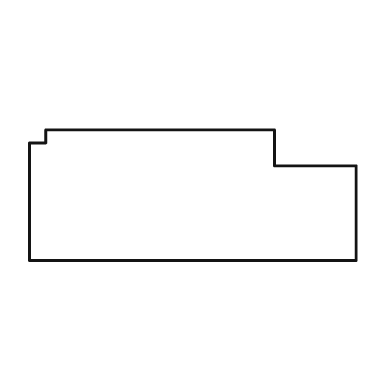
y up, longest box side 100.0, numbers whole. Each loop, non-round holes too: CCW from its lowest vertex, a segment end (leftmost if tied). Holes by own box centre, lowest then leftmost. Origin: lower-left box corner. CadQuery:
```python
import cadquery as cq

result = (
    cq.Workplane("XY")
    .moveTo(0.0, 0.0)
    .lineTo(100.0, 0.0)
    .lineTo(100.0, 29.0)
    .lineTo(75.0, 29.0)
    .lineTo(75.0, 40.0)
    .lineTo(5.0, 40.0)
    .lineTo(5.0, 36.0)
    .lineTo(0.0, 36.0)
    .close()
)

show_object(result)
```